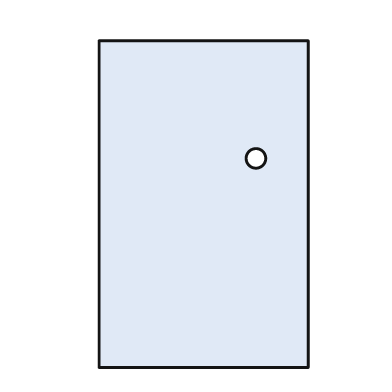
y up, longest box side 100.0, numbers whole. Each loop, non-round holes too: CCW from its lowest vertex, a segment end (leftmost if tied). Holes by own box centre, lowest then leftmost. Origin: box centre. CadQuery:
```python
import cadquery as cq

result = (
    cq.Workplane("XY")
    .moveTo(-32.0, -50.0)
    .lineTo(32.0, -50.0)
    .lineTo(32.0, 50.0)
    .lineTo(-32.0, 50.0)
    .close()
    .moveTo(16.0, 14.0)
    .circle(3.0)
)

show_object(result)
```